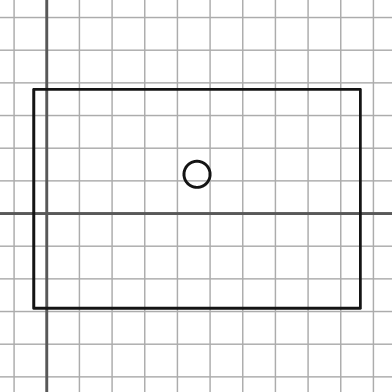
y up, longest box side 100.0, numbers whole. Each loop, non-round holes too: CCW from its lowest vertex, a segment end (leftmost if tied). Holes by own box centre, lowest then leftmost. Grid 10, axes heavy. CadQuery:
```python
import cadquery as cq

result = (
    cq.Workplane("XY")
    .moveTo(-4.0, -29.0)
    .lineTo(96.0, -29.0)
    .lineTo(96.0, 38.0)
    .lineTo(-4.0, 38.0)
    .close()
    .moveTo(46.0, 12.0)
    .circle(4.0)
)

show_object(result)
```